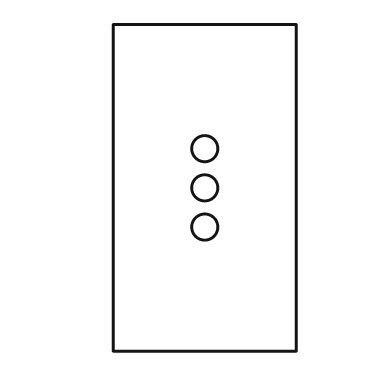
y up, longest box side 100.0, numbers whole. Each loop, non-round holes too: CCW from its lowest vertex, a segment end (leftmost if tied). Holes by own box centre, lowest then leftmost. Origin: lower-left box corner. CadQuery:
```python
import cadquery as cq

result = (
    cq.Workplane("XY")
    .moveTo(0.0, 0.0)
    .lineTo(56.0, 0.0)
    .lineTo(56.0, 100.0)
    .lineTo(0.0, 100.0)
    .close()
    .moveTo(28.0, 38.0)
    .circle(4.0)
    .moveTo(28.0, 50.0)
    .circle(4.0)
    .moveTo(28.0, 62.0)
    .circle(4.0)
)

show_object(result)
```